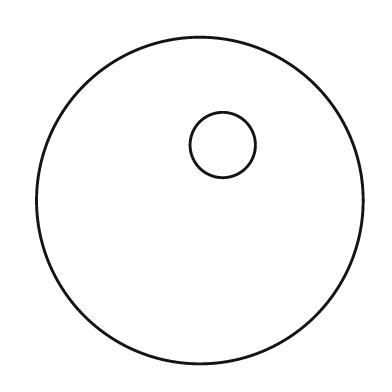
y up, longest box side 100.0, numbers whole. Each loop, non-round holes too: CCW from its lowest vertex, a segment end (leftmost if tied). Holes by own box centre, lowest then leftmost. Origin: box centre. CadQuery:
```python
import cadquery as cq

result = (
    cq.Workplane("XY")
    .moveTo(0.0, 0.0)
    .circle(50.0)
    .moveTo(7.0, 17.0)
    .circle(10.0)
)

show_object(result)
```